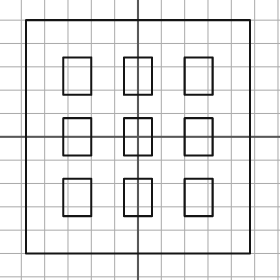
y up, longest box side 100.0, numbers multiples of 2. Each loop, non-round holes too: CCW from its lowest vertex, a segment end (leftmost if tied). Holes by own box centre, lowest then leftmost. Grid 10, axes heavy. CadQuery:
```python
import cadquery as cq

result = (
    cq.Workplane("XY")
    .moveTo(-48.0, -50.0)
    .lineTo(48.0, -50.0)
    .lineTo(48.0, 50.0)
    .lineTo(-48.0, 50.0)
    .close()
    .moveTo(-32.0, -34.0)
    .lineTo(-20.0, -34.0)
    .lineTo(-20.0, -18.0)
    .lineTo(-32.0, -18.0)
    .close()
    .moveTo(-6.0, -34.0)
    .lineTo(6.0, -34.0)
    .lineTo(6.0, -18.0)
    .lineTo(-6.0, -18.0)
    .close()
    .moveTo(20.0, -34.0)
    .lineTo(32.0, -34.0)
    .lineTo(32.0, -18.0)
    .lineTo(20.0, -18.0)
    .close()
    .moveTo(-32.0, -8.0)
    .lineTo(-20.0, -8.0)
    .lineTo(-20.0, 8.0)
    .lineTo(-32.0, 8.0)
    .close()
    .moveTo(-6.0, -8.0)
    .lineTo(6.0, -8.0)
    .lineTo(6.0, 8.0)
    .lineTo(-6.0, 8.0)
    .close()
    .moveTo(20.0, -8.0)
    .lineTo(32.0, -8.0)
    .lineTo(32.0, 8.0)
    .lineTo(20.0, 8.0)
    .close()
    .moveTo(-32.0, 18.0)
    .lineTo(-20.0, 18.0)
    .lineTo(-20.0, 34.0)
    .lineTo(-32.0, 34.0)
    .close()
    .moveTo(-6.0, 18.0)
    .lineTo(6.0, 18.0)
    .lineTo(6.0, 34.0)
    .lineTo(-6.0, 34.0)
    .close()
    .moveTo(20.0, 18.0)
    .lineTo(32.0, 18.0)
    .lineTo(32.0, 34.0)
    .lineTo(20.0, 34.0)
    .close()
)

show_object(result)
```